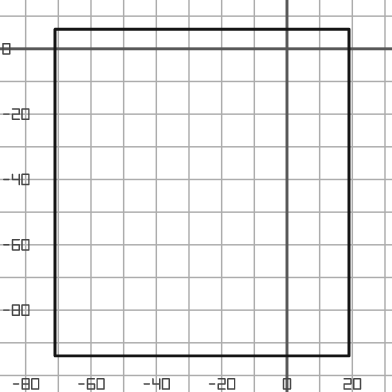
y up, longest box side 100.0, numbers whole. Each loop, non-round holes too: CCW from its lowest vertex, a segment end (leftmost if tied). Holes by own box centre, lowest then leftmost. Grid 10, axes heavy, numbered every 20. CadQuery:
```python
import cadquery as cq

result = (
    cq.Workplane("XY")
    .moveTo(-71.0, -94.0)
    .lineTo(19.0, -94.0)
    .lineTo(19.0, 6.0)
    .lineTo(-71.0, 6.0)
    .close()
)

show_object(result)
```